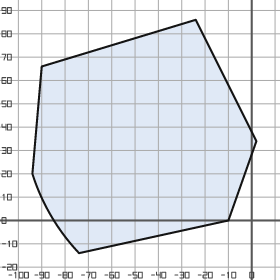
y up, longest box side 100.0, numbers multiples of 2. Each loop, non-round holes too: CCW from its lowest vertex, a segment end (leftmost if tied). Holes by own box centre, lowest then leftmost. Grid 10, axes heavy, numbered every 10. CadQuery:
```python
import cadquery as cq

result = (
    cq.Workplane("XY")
    .moveTo(-74.0, -14.0)
    .lineTo(-10.0, 0.0)
    .lineTo(2.0, 34.0)
    .lineTo(-24.0, 86.0)
    .lineTo(-90.0, 66.0)
    .lineTo(-94.0, 20.0)
    .threePointArc((-86.0, 2.0), (-74.0, -14.0))
    .close()
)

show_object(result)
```